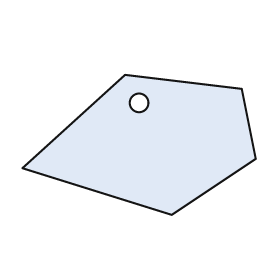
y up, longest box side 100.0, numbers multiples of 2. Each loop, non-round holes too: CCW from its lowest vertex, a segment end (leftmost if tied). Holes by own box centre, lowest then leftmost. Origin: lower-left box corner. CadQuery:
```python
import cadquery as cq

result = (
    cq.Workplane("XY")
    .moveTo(64.0, 0.0)
    .lineTo(100.0, 24.0)
    .lineTo(94.0, 54.0)
    .lineTo(44.0, 60.0)
    .lineTo(0.0, 20.0)
    .close()
    .moveTo(50.0, 48.0)
    .circle(4.0)
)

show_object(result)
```